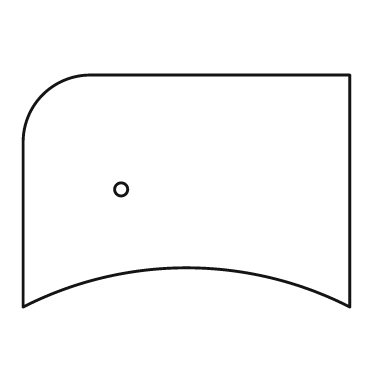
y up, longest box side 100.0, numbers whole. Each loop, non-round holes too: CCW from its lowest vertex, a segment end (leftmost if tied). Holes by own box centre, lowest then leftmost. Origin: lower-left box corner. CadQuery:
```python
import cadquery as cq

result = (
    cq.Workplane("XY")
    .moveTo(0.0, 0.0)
    .threePointArc((50.0, 12.0), (100.0, 0.0))
    .lineTo(100.0, 71.0)
    .lineTo(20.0, 71.0)
    .threePointArc((6.0, 65.0), (0.0, 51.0))
    .close()
    .moveTo(30.0, 36.0)
    .circle(2.0)
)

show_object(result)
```